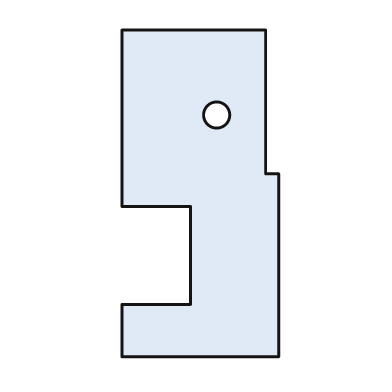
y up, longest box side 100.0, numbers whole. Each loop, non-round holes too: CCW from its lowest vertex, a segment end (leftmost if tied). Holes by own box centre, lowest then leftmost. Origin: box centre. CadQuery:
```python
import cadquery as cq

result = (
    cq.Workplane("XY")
    .moveTo(-24.0, -50.0)
    .lineTo(24.0, -50.0)
    .lineTo(24.0, 6.0)
    .lineTo(20.0, 6.0)
    .lineTo(20.0, 50.0)
    .lineTo(-24.0, 50.0)
    .lineTo(-24.0, -4.0)
    .lineTo(-3.0, -4.0)
    .lineTo(-3.0, -34.0)
    .lineTo(-24.0, -34.0)
    .close()
    .moveTo(5.0, 24.0)
    .circle(4.0)
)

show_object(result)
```